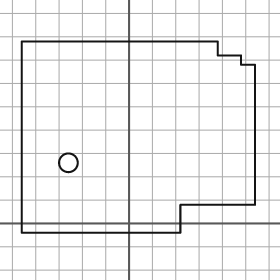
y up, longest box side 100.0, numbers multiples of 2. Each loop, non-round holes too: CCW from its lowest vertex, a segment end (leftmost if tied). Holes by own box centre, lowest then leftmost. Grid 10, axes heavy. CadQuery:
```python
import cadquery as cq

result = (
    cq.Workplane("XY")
    .moveTo(-46.0, -4.0)
    .lineTo(22.0, -4.0)
    .lineTo(22.0, 8.0)
    .lineTo(54.0, 8.0)
    .lineTo(54.0, 68.0)
    .lineTo(48.0, 68.0)
    .lineTo(48.0, 72.0)
    .lineTo(38.0, 72.0)
    .lineTo(38.0, 78.0)
    .lineTo(-46.0, 78.0)
    .close()
    .moveTo(-26.0, 26.0)
    .circle(4.0)
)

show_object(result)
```